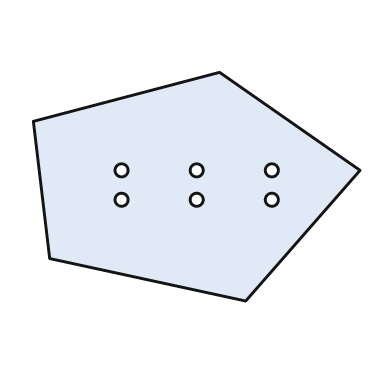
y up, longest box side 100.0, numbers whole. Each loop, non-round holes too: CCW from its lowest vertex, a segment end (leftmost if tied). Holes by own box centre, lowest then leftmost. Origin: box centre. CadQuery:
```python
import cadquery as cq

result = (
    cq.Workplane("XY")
    .moveTo(15.0, -35.0)
    .lineTo(50.0, 5.0)
    .lineTo(7.0, 35.0)
    .lineTo(-50.0, 20.0)
    .lineTo(-45.0, -22.0)
    .close()
    .moveTo(-23.0, -4.0)
    .circle(2.0)
    .moveTo(0.0, -4.0)
    .circle(2.0)
    .moveTo(23.0, -4.0)
    .circle(2.0)
    .moveTo(-23.0, 5.0)
    .circle(2.0)
    .moveTo(0.0, 5.0)
    .circle(2.0)
    .moveTo(23.0, 5.0)
    .circle(2.0)
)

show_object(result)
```